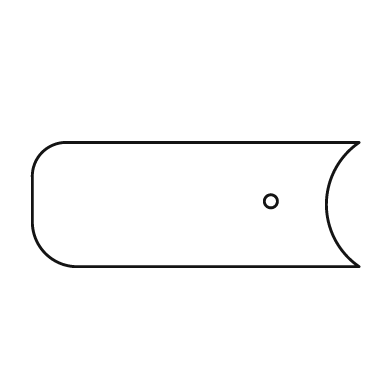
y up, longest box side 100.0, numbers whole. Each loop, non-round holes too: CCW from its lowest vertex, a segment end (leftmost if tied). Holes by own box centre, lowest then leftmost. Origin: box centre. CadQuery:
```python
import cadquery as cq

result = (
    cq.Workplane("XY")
    .moveTo(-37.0, -19.0)
    .lineTo(50.0, -19.0)
    .threePointArc((40.0, 0.0), (50.0, 19.0))
    .lineTo(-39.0, 19.0)
    .threePointArc((-47.0, 16.0), (-50.0, 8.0))
    .lineTo(-50.0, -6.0)
    .threePointArc((-46.0, -15.0), (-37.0, -19.0))
    .close()
    .moveTo(23.0, 1.0)
    .circle(2.0)
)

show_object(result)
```